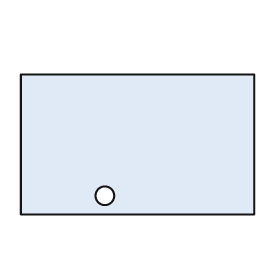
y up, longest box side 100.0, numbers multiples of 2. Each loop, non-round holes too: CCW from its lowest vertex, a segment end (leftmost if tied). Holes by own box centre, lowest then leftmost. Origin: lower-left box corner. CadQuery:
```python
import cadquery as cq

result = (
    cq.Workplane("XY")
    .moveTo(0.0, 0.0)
    .lineTo(100.0, 0.0)
    .lineTo(100.0, 60.0)
    .lineTo(0.0, 60.0)
    .close()
    .moveTo(36.0, 8.0)
    .circle(4.0)
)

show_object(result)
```